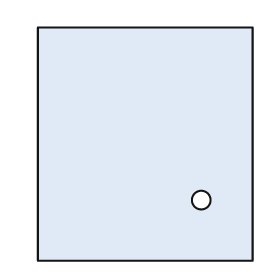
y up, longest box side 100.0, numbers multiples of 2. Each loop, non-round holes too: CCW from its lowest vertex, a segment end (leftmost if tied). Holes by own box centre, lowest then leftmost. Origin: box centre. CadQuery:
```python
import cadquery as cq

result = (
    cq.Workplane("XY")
    .moveTo(-46.0, -50.0)
    .lineTo(46.0, -50.0)
    .lineTo(46.0, 50.0)
    .lineTo(-46.0, 50.0)
    .close()
    .moveTo(24.0, -24.0)
    .circle(4.0)
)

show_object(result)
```